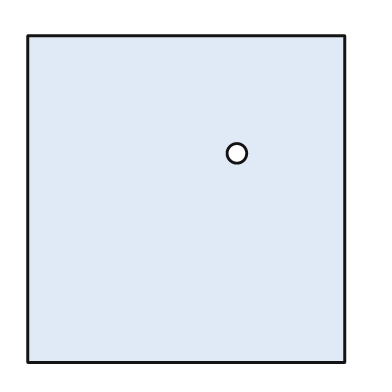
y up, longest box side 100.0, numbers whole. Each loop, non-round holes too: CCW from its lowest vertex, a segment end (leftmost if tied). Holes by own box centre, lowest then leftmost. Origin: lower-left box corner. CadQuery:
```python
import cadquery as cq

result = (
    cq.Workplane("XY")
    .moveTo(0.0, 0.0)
    .lineTo(97.0, 0.0)
    .lineTo(97.0, 100.0)
    .lineTo(0.0, 100.0)
    .close()
    .moveTo(64.0, 64.0)
    .circle(3.0)
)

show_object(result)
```